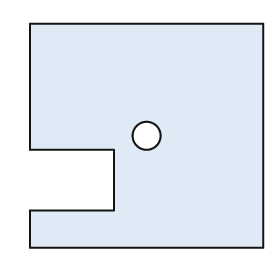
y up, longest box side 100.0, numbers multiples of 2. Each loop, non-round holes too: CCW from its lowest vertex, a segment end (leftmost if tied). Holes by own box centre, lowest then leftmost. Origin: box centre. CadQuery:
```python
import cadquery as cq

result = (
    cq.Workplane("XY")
    .moveTo(-50.0, -48.0)
    .lineTo(50.0, -48.0)
    .lineTo(50.0, 48.0)
    .lineTo(-50.0, 48.0)
    .lineTo(-50.0, -6.0)
    .lineTo(-14.0, -6.0)
    .lineTo(-14.0, -32.0)
    .lineTo(-50.0, -32.0)
    .close()
    .moveTo(0.0, 0.0)
    .circle(6.0)
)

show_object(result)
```